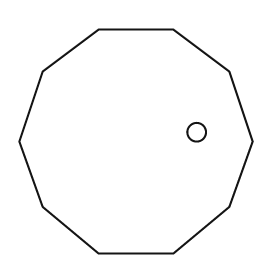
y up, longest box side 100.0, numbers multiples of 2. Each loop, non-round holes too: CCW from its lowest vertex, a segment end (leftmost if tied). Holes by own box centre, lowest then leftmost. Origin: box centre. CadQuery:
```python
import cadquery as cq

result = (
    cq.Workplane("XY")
    .moveTo(-16.0, -48.0)
    .lineTo(16.0, -48.0)
    .lineTo(40.0, -28.0)
    .lineTo(50.0, 0.0)
    .lineTo(40.0, 30.0)
    .lineTo(16.0, 48.0)
    .lineTo(-16.0, 48.0)
    .lineTo(-40.0, 30.0)
    .lineTo(-50.0, 0.0)
    .lineTo(-40.0, -28.0)
    .close()
    .moveTo(26.0, 4.0)
    .circle(4.0)
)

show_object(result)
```